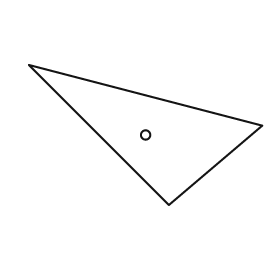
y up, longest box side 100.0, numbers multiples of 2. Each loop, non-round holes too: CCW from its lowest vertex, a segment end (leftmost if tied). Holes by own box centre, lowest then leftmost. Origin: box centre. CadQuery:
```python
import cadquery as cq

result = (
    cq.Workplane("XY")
    .moveTo(10.0, -30.0)
    .lineTo(50.0, 4.0)
    .lineTo(-50.0, 30.0)
    .close()
    .moveTo(0.0, 0.0)
    .circle(2.0)
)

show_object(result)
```